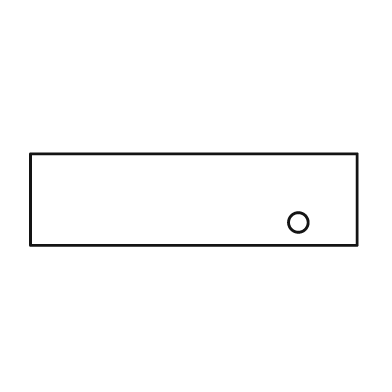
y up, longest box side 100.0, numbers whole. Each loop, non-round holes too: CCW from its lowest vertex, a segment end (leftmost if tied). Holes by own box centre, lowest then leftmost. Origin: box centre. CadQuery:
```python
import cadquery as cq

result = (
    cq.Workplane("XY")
    .moveTo(-50.0, -14.0)
    .lineTo(50.0, -14.0)
    .lineTo(50.0, 14.0)
    .lineTo(-50.0, 14.0)
    .close()
    .moveTo(32.0, -7.0)
    .circle(3.0)
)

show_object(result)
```